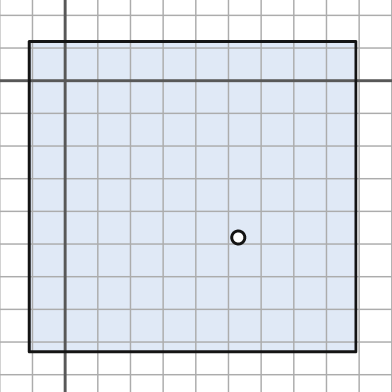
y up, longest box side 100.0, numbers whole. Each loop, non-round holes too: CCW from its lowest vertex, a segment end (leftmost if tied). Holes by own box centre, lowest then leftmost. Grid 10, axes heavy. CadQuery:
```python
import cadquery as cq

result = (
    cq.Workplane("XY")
    .moveTo(-11.0, -83.0)
    .lineTo(89.0, -83.0)
    .lineTo(89.0, 12.0)
    .lineTo(-11.0, 12.0)
    .close()
    .moveTo(53.0, -48.0)
    .circle(2.0)
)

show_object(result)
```